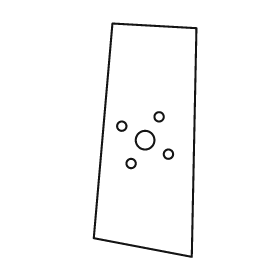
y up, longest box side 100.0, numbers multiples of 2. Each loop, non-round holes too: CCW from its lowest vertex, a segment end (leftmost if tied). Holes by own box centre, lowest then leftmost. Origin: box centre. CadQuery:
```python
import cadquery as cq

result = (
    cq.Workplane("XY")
    .moveTo(20.0, -50.0)
    .lineTo(22.0, 48.0)
    .lineTo(-14.0, 50.0)
    .lineTo(-22.0, -42.0)
    .close()
    .moveTo(-6.0, -10.0)
    .circle(2.0)
    .moveTo(10.0, -6.0)
    .circle(2.0)
    .moveTo(0.0, 0.0)
    .circle(4.0)
    .moveTo(-10.0, 6.0)
    .circle(2.0)
    .moveTo(6.0, 10.0)
    .circle(2.0)
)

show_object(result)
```